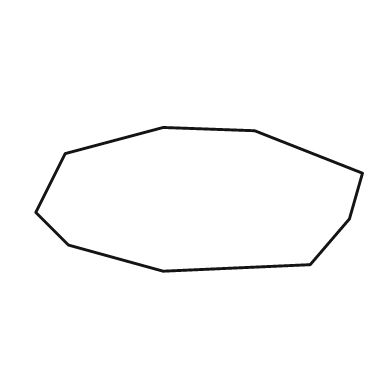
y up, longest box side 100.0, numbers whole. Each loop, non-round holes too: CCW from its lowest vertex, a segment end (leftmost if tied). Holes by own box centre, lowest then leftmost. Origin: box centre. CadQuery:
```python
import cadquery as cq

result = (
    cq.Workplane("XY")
    .moveTo(-11.0, -22.0)
    .lineTo(34.0, -20.0)
    .lineTo(46.0, -6.0)
    .lineTo(50.0, 8.0)
    .lineTo(17.0, 21.0)
    .lineTo(-11.0, 22.0)
    .lineTo(-41.0, 14.0)
    .lineTo(-50.0, -4.0)
    .lineTo(-40.0, -14.0)
    .close()
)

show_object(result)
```